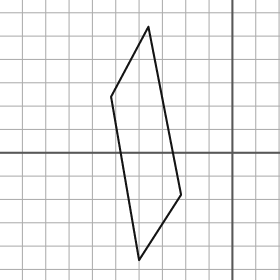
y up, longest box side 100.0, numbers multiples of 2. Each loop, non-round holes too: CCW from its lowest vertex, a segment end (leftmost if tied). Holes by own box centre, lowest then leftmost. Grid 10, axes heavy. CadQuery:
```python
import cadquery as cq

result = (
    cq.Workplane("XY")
    .moveTo(-40.0, -46.0)
    .lineTo(-22.0, -18.0)
    .lineTo(-36.0, 54.0)
    .lineTo(-52.0, 24.0)
    .close()
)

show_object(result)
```